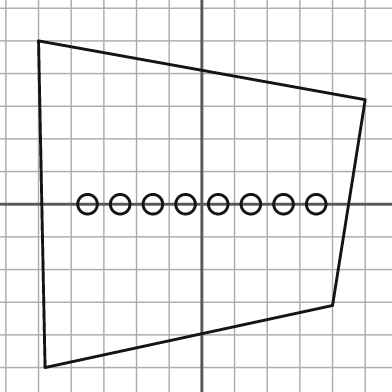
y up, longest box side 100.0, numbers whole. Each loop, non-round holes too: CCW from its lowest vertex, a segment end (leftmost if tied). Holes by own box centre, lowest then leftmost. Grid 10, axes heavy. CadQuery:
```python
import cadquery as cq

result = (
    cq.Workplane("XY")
    .moveTo(-48.0, -50.0)
    .lineTo(40.0, -31.0)
    .lineTo(50.0, 32.0)
    .lineTo(-50.0, 50.0)
    .close()
    .moveTo(-35.0, 0.0)
    .circle(3.0)
    .moveTo(-25.0, 0.0)
    .circle(3.0)
    .moveTo(-15.0, 0.0)
    .circle(3.0)
    .moveTo(-5.0, 0.0)
    .circle(3.0)
    .moveTo(5.0, 0.0)
    .circle(3.0)
    .moveTo(15.0, 0.0)
    .circle(3.0)
    .moveTo(25.0, 0.0)
    .circle(3.0)
    .moveTo(35.0, 0.0)
    .circle(3.0)
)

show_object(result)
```